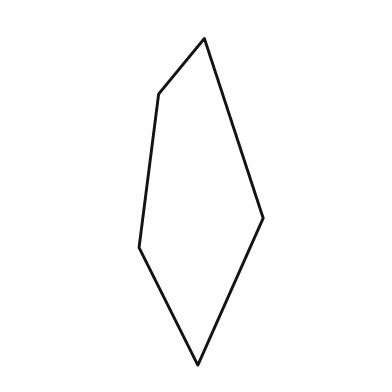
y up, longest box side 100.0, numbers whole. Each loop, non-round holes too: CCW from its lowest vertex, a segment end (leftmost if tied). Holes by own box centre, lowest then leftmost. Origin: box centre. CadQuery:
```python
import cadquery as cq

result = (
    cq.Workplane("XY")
    .moveTo(-1.0, -50.0)
    .lineTo(19.0, -5.0)
    .lineTo(1.0, 50.0)
    .lineTo(-13.0, 33.0)
    .lineTo(-19.0, -14.0)
    .close()
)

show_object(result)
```